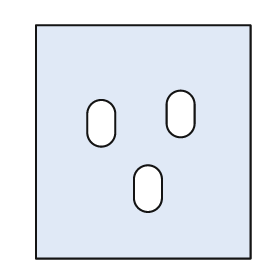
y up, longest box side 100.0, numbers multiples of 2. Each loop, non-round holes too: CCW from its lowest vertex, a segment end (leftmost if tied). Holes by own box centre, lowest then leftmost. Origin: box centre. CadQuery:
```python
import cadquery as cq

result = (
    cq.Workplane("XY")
    .moveTo(-46.0, -50.0)
    .lineTo(46.0, -50.0)
    .lineTo(46.0, 50.0)
    .lineTo(-46.0, 50.0)
    .close()
    .moveTo(-4.0, -24.0)
    .threePointArc((2.0, -30.0), (8.0, -24.0))
    .lineTo(8.0, -16.0)
    .threePointArc((2.0, -10.0), (-4.0, -16.0))
    .close()
    .moveTo(-24.0, 4.0)
    .threePointArc((-18.0, -2.0), (-12.0, 4.0))
    .lineTo(-12.0, 12.0)
    .threePointArc((-18.0, 18.0), (-24.0, 12.0))
    .close()
    .moveTo(10.0, 8.0)
    .threePointArc((16.0, 2.0), (22.0, 8.0))
    .lineTo(22.0, 16.0)
    .threePointArc((16.0, 22.0), (10.0, 16.0))
    .close()
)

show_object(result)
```